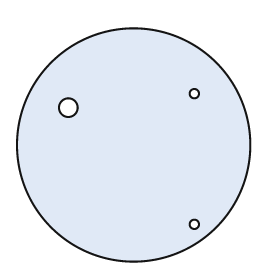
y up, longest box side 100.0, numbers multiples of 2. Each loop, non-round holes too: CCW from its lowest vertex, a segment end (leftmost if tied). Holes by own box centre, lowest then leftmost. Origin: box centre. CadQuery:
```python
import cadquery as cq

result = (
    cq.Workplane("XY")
    .moveTo(0.0, 0.0)
    .circle(50.0)
    .moveTo(26.0, -34.0)
    .circle(2.0)
    .moveTo(-28.0, 16.0)
    .circle(4.0)
    .moveTo(26.0, 22.0)
    .circle(2.0)
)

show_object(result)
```